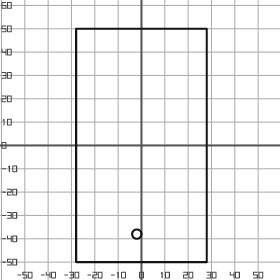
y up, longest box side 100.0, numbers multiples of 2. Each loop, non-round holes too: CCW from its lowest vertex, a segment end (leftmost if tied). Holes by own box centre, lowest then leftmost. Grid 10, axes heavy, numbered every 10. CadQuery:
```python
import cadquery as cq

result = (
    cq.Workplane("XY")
    .moveTo(-28.0, -50.0)
    .lineTo(28.0, -50.0)
    .lineTo(28.0, 50.0)
    .lineTo(-28.0, 50.0)
    .close()
    .moveTo(-2.0, -38.0)
    .circle(2.0)
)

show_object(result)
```